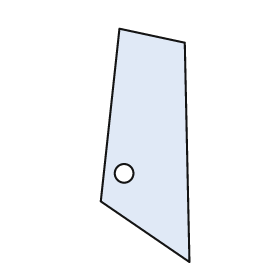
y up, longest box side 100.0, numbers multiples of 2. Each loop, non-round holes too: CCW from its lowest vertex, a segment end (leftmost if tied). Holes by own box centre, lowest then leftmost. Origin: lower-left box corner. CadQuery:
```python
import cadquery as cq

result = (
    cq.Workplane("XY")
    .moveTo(38.0, 0.0)
    .lineTo(36.0, 94.0)
    .lineTo(8.0, 100.0)
    .lineTo(0.0, 26.0)
    .close()
    .moveTo(10.0, 38.0)
    .circle(4.0)
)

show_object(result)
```